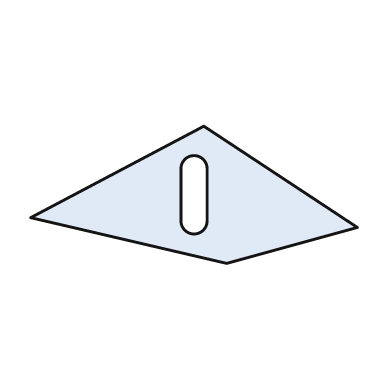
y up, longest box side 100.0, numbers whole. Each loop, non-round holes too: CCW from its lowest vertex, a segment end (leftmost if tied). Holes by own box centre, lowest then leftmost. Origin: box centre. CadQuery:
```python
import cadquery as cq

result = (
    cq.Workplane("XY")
    .moveTo(10.0, -21.0)
    .lineTo(50.0, -10.0)
    .lineTo(3.0, 21.0)
    .lineTo(-50.0, -7.0)
    .close()
    .moveTo(-4.0, -8.0)
    .threePointArc((0.0, -12.0), (4.0, -8.0))
    .lineTo(4.0, 8.0)
    .threePointArc((0.0, 12.0), (-4.0, 8.0))
    .close()
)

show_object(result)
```